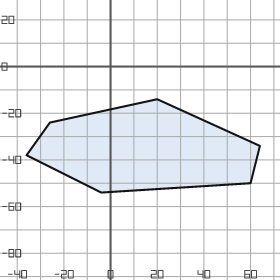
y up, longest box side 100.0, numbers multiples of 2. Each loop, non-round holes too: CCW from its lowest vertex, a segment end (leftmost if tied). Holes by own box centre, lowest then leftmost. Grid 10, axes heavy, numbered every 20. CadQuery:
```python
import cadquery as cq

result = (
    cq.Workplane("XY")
    .moveTo(-4.0, -54.0)
    .lineTo(60.0, -50.0)
    .lineTo(64.0, -34.0)
    .lineTo(20.0, -14.0)
    .lineTo(-26.0, -24.0)
    .lineTo(-36.0, -38.0)
    .close()
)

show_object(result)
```